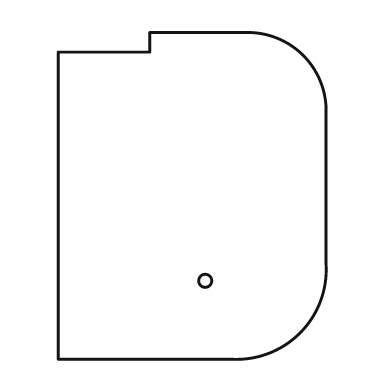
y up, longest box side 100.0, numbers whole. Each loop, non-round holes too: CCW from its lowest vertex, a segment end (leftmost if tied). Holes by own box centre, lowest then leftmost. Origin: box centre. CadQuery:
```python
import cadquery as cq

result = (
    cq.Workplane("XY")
    .moveTo(-41.0, -50.0)
    .lineTo(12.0, -50.0)
    .threePointArc((33.0, -42.0), (41.0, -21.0))
    .lineTo(41.0, 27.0)
    .threePointArc((34.0, 43.0), (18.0, 50.0))
    .lineTo(-13.0, 50.0)
    .lineTo(-13.0, 44.0)
    .lineTo(-41.0, 44.0)
    .close()
    .moveTo(4.0, -26.0)
    .circle(2.0)
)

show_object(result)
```